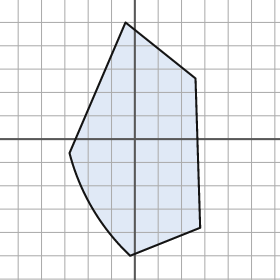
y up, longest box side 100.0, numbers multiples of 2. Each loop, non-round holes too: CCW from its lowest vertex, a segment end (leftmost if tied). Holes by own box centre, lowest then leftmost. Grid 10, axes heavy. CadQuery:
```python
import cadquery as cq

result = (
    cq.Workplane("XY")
    .moveTo(-2.0, -50.0)
    .lineTo(28.0, -38.0)
    .lineTo(26.0, 26.0)
    .lineTo(-4.0, 50.0)
    .lineTo(-28.0, -6.0)
    .threePointArc((-18.0, -30.0), (-2.0, -50.0))
    .close()
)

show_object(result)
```